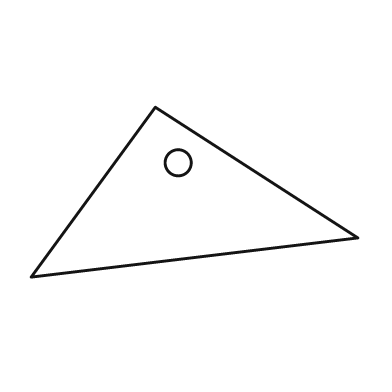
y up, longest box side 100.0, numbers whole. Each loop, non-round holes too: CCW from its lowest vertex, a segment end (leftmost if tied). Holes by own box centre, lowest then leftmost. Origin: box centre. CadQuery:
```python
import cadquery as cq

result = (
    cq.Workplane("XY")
    .moveTo(-50.0, -26.0)
    .lineTo(50.0, -14.0)
    .lineTo(-12.0, 26.0)
    .close()
    .moveTo(-5.0, 9.0)
    .circle(4.0)
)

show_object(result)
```